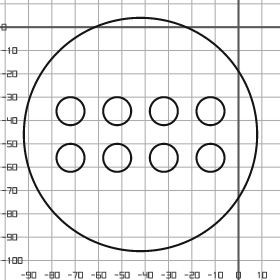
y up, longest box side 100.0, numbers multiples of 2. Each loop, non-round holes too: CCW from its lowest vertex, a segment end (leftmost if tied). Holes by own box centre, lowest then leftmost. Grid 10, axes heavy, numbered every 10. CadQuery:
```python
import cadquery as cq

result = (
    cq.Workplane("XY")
    .moveTo(-42.0, -46.0)
    .circle(50.0)
    .moveTo(-72.0, -56.0)
    .circle(6.0)
    .moveTo(-52.0, -56.0)
    .circle(6.0)
    .moveTo(-32.0, -56.0)
    .circle(6.0)
    .moveTo(-12.0, -56.0)
    .circle(6.0)
    .moveTo(-72.0, -36.0)
    .circle(6.0)
    .moveTo(-52.0, -36.0)
    .circle(6.0)
    .moveTo(-32.0, -36.0)
    .circle(6.0)
    .moveTo(-12.0, -36.0)
    .circle(6.0)
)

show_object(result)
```